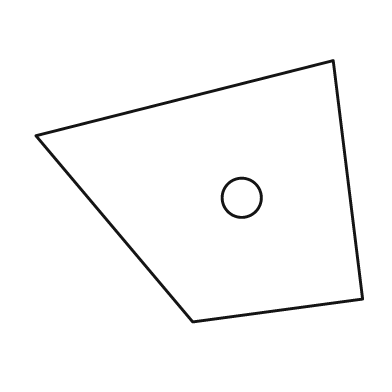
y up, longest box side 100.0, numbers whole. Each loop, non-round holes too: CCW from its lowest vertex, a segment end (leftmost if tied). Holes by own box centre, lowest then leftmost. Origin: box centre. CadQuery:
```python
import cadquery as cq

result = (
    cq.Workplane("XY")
    .moveTo(-2.0, -40.0)
    .lineTo(50.0, -33.0)
    .lineTo(41.0, 40.0)
    .lineTo(-50.0, 17.0)
    .close()
    .moveTo(13.0, -2.0)
    .circle(6.0)
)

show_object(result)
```